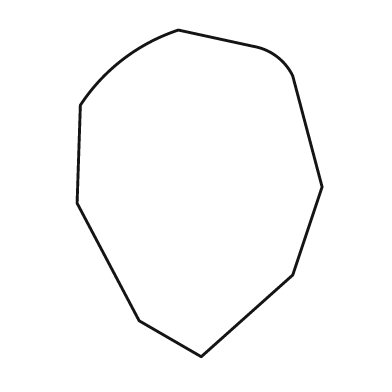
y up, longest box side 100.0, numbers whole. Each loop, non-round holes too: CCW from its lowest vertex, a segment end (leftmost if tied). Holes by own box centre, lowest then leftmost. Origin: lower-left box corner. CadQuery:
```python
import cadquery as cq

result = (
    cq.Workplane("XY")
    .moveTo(38.0, 0.0)
    .lineTo(66.0, 25.0)
    .lineTo(75.0, 52.0)
    .lineTo(66.0, 86.0)
    .threePointArc((61.0, 92.0), (54.0, 95.0))
    .lineTo(31.0, 100.0)
    .threePointArc((14.0, 91.0), (1.0, 77.0))
    .lineTo(0.0, 47.0)
    .lineTo(19.0, 11.0)
    .close()
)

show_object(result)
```